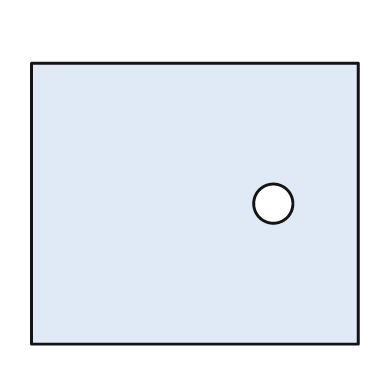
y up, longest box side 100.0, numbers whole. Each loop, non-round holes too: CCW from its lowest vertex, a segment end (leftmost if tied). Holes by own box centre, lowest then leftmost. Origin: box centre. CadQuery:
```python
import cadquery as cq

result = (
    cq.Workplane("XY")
    .moveTo(-50.0, -43.0)
    .lineTo(50.0, -43.0)
    .lineTo(50.0, 43.0)
    .lineTo(-50.0, 43.0)
    .close()
    .moveTo(24.0, 0.0)
    .circle(6.0)
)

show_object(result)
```